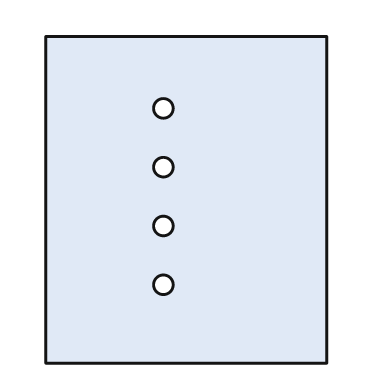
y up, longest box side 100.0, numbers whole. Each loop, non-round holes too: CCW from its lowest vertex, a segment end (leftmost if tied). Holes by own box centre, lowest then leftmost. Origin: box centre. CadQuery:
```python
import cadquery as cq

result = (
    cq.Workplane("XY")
    .moveTo(-43.0, -50.0)
    .lineTo(43.0, -50.0)
    .lineTo(43.0, 50.0)
    .lineTo(-43.0, 50.0)
    .close()
    .moveTo(-7.0, -26.0)
    .circle(3.0)
    .moveTo(-7.0, -8.0)
    .circle(3.0)
    .moveTo(-7.0, 10.0)
    .circle(3.0)
    .moveTo(-7.0, 28.0)
    .circle(3.0)
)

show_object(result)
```